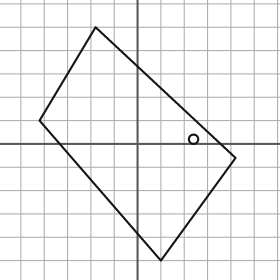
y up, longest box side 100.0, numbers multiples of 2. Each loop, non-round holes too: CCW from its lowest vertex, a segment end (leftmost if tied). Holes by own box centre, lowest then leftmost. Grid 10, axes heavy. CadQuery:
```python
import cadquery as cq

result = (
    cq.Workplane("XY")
    .moveTo(10.0, -50.0)
    .lineTo(42.0, -6.0)
    .lineTo(-18.0, 50.0)
    .lineTo(-42.0, 10.0)
    .close()
    .moveTo(24.0, 2.0)
    .circle(2.0)
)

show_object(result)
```